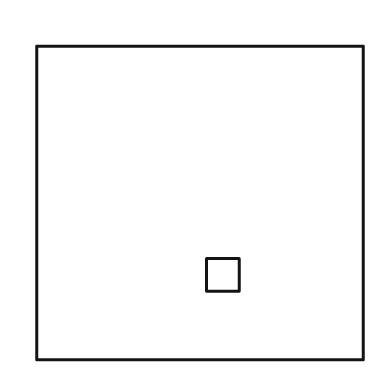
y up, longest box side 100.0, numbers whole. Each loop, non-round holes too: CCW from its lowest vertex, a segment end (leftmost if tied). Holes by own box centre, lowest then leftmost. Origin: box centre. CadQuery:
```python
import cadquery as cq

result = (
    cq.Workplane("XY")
    .moveTo(-50.0, -48.0)
    .lineTo(50.0, -48.0)
    .lineTo(50.0, 48.0)
    .lineTo(-50.0, 48.0)
    .close()
    .moveTo(2.0, -27.0)
    .lineTo(12.0, -27.0)
    .lineTo(12.0, -17.0)
    .lineTo(2.0, -17.0)
    .close()
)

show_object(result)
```